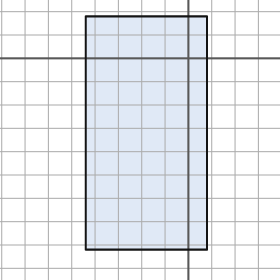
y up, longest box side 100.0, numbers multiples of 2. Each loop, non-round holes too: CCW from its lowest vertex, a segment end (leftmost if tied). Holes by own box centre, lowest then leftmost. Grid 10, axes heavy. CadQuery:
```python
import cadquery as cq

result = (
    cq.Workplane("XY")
    .moveTo(-44.0, -82.0)
    .lineTo(8.0, -82.0)
    .lineTo(8.0, 18.0)
    .lineTo(-44.0, 18.0)
    .close()
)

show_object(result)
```